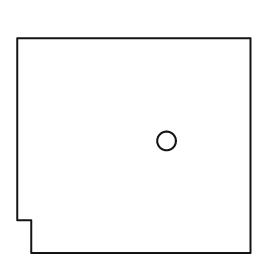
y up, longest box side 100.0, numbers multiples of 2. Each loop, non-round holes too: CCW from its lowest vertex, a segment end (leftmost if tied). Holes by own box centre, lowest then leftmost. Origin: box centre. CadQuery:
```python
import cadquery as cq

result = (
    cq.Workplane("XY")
    .moveTo(-44.0, -46.0)
    .lineTo(50.0, -46.0)
    .lineTo(50.0, 46.0)
    .lineTo(-50.0, 46.0)
    .lineTo(-50.0, -32.0)
    .lineTo(-44.0, -32.0)
    .close()
    .moveTo(14.0, 2.0)
    .circle(4.0)
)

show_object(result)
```